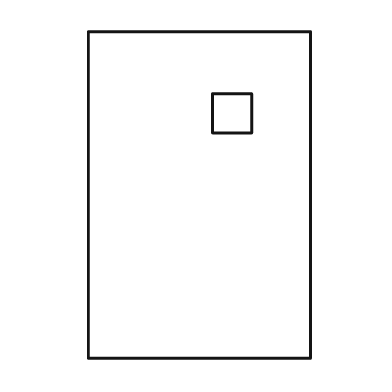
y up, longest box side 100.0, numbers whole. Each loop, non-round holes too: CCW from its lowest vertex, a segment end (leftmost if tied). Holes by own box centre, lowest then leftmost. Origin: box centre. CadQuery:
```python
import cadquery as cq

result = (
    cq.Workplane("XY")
    .moveTo(-34.0, -50.0)
    .lineTo(34.0, -50.0)
    .lineTo(34.0, 50.0)
    .lineTo(-34.0, 50.0)
    .close()
    .moveTo(4.0, 19.0)
    .lineTo(16.0, 19.0)
    .lineTo(16.0, 31.0)
    .lineTo(4.0, 31.0)
    .close()
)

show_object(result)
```